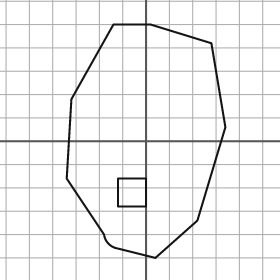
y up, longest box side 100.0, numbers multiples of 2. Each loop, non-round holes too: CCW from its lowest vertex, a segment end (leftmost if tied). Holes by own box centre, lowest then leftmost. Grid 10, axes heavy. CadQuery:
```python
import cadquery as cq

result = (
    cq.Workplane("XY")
    .moveTo(4.0, -50.0)
    .lineTo(22.0, -34.0)
    .lineTo(34.0, 6.0)
    .lineTo(28.0, 42.0)
    .lineTo(2.0, 50.0)
    .lineTo(-14.0, 50.0)
    .lineTo(-32.0, 18.0)
    .lineTo(-34.0, -16.0)
    .lineTo(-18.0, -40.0)
    .threePointArc((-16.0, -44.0), (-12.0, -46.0))
    .close()
    .moveTo(-12.0, -28.0)
    .lineTo(0.0, -28.0)
    .lineTo(0.0, -16.0)
    .lineTo(-12.0, -16.0)
    .close()
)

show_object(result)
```